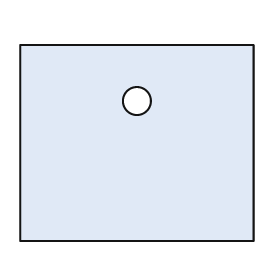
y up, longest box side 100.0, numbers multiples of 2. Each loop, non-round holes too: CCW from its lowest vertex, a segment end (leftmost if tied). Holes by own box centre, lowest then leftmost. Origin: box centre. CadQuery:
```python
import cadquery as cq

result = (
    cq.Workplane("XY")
    .moveTo(-50.0, -42.0)
    .lineTo(50.0, -42.0)
    .lineTo(50.0, 42.0)
    .lineTo(-50.0, 42.0)
    .close()
    .moveTo(0.0, 18.0)
    .circle(6.0)
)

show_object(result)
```